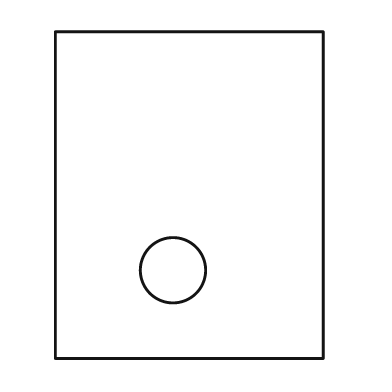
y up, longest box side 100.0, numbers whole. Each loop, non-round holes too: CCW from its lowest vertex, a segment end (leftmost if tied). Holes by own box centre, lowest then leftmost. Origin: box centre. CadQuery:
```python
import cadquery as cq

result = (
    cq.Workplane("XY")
    .moveTo(-41.0, -50.0)
    .lineTo(41.0, -50.0)
    .lineTo(41.0, 50.0)
    .lineTo(-41.0, 50.0)
    .close()
    .moveTo(-5.0, -23.0)
    .circle(10.0)
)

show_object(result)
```